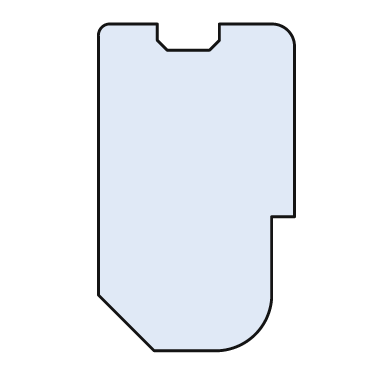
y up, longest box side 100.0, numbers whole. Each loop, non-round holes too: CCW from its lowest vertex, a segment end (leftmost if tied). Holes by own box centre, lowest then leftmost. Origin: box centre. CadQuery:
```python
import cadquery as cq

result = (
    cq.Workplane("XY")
    .moveTo(-13.0, -50.0)
    .lineTo(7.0, -50.0)
    .threePointArc((18.0, -45.0), (23.0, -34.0))
    .lineTo(23.0, -9.0)
    .lineTo(30.0, -9.0)
    .lineTo(30.0, 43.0)
    .threePointArc((28.0, 48.0), (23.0, 50.0))
    .lineTo(7.0, 50.0)
    .lineTo(7.0, 45.0)
    .lineTo(4.0, 42.0)
    .lineTo(-9.0, 42.0)
    .lineTo(-12.0, 45.0)
    .lineTo(-12.0, 50.0)
    .lineTo(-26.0, 50.0)
    .threePointArc((-29.0, 49.0), (-30.0, 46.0))
    .lineTo(-30.0, -33.0)
    .close()
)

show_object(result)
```